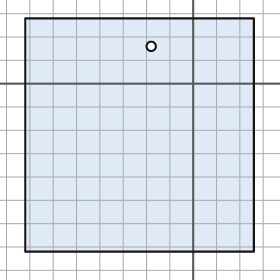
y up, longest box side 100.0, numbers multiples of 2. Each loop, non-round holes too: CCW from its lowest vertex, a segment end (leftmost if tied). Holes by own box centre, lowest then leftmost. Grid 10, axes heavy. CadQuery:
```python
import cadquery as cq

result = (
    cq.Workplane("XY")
    .moveTo(-72.0, -72.0)
    .lineTo(26.0, -72.0)
    .lineTo(26.0, 28.0)
    .lineTo(-72.0, 28.0)
    .close()
    .moveTo(-18.0, 16.0)
    .circle(2.0)
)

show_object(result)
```